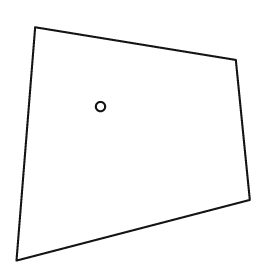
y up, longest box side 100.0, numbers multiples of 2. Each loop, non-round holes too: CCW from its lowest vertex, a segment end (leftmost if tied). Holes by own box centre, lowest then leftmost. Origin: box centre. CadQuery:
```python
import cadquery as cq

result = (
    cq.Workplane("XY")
    .moveTo(-50.0, -50.0)
    .lineTo(50.0, -24.0)
    .lineTo(44.0, 36.0)
    .lineTo(-42.0, 50.0)
    .close()
    .moveTo(-14.0, 16.0)
    .circle(2.0)
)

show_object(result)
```